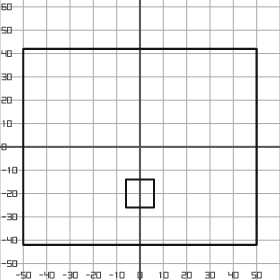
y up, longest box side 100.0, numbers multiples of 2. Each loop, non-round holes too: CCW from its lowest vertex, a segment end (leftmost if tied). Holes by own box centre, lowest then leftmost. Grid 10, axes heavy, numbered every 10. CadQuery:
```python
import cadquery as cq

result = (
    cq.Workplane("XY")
    .moveTo(-50.0, -42.0)
    .lineTo(50.0, -42.0)
    .lineTo(50.0, 42.0)
    .lineTo(-50.0, 42.0)
    .close()
    .moveTo(-6.0, -26.0)
    .lineTo(6.0, -26.0)
    .lineTo(6.0, -14.0)
    .lineTo(-6.0, -14.0)
    .close()
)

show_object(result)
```